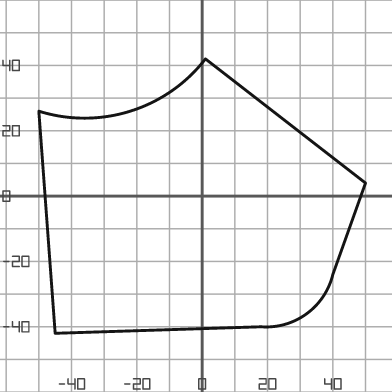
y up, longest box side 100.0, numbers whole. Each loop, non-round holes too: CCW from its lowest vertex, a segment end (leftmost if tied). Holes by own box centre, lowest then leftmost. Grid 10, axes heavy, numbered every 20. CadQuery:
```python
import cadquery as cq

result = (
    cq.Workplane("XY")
    .moveTo(-45.0, -42.0)
    .lineTo(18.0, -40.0)
    .threePointArc((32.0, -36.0), (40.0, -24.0))
    .lineTo(50.0, 4.0)
    .lineTo(1.0, 42.0)
    .threePointArc((-22.0, 26.0), (-50.0, 26.0))
    .close()
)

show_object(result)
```